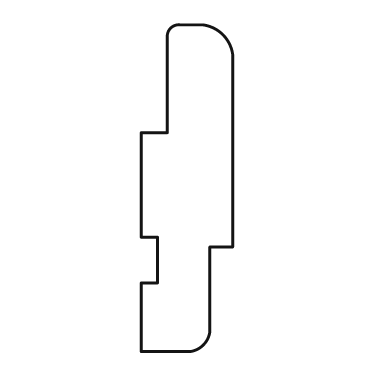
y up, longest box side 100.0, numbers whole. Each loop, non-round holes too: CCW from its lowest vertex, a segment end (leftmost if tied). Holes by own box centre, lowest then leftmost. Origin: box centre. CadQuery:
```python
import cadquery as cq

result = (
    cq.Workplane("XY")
    .moveTo(-14.0, -50.0)
    .lineTo(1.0, -50.0)
    .threePointArc((5.0, -48.0), (7.0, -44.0))
    .lineTo(7.0, -18.0)
    .lineTo(14.0, -18.0)
    .lineTo(14.0, 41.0)
    .threePointArc((11.0, 47.0), (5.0, 50.0))
    .lineTo(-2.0, 50.0)
    .threePointArc((-5.0, 49.0), (-6.0, 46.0))
    .lineTo(-6.0, 17.0)
    .lineTo(-14.0, 17.0)
    .lineTo(-14.0, -15.0)
    .lineTo(-9.0, -15.0)
    .lineTo(-9.0, -29.0)
    .lineTo(-14.0, -29.0)
    .close()
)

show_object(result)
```